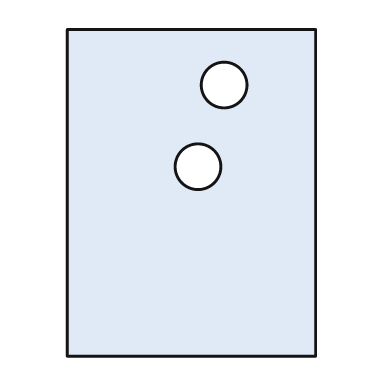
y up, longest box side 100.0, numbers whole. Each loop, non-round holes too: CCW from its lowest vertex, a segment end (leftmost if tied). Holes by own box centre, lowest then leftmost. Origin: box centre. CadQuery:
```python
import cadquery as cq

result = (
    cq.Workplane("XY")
    .moveTo(-38.0, -50.0)
    .lineTo(38.0, -50.0)
    .lineTo(38.0, 50.0)
    .lineTo(-38.0, 50.0)
    .close()
    .moveTo(2.0, 8.0)
    .circle(7.0)
    .moveTo(10.0, 33.0)
    .circle(7.0)
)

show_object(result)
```